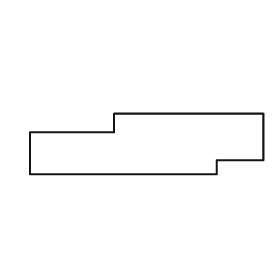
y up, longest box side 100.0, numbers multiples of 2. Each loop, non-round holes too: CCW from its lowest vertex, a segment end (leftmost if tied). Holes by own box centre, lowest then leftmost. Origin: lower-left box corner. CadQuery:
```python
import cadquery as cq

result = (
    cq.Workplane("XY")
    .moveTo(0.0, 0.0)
    .lineTo(80.0, 0.0)
    .lineTo(80.0, 6.0)
    .lineTo(100.0, 6.0)
    .lineTo(100.0, 26.0)
    .lineTo(36.0, 26.0)
    .lineTo(36.0, 18.0)
    .lineTo(0.0, 18.0)
    .close()
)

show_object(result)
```